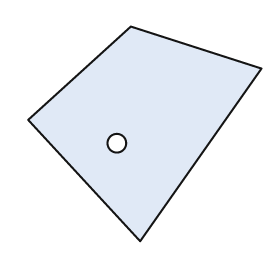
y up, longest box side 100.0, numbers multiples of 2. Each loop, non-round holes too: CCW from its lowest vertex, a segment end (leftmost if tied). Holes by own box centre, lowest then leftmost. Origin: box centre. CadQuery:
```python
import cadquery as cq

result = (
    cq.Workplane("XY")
    .moveTo(-2.0, -46.0)
    .lineTo(50.0, 28.0)
    .lineTo(-6.0, 46.0)
    .lineTo(-50.0, 6.0)
    .close()
    .moveTo(-12.0, -4.0)
    .circle(4.0)
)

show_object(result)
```